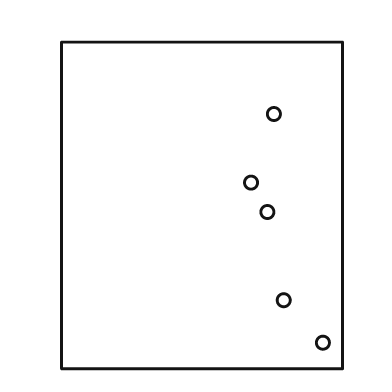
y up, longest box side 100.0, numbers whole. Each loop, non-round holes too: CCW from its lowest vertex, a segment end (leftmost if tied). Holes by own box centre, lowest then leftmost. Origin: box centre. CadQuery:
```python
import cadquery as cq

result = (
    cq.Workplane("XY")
    .moveTo(-43.0, -50.0)
    .lineTo(43.0, -50.0)
    .lineTo(43.0, 50.0)
    .lineTo(-43.0, 50.0)
    .close()
    .moveTo(37.0, -42.0)
    .circle(2.0)
    .moveTo(25.0, -29.0)
    .circle(2.0)
    .moveTo(20.0, -2.0)
    .circle(2.0)
    .moveTo(15.0, 7.0)
    .circle(2.0)
    .moveTo(22.0, 28.0)
    .circle(2.0)
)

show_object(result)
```